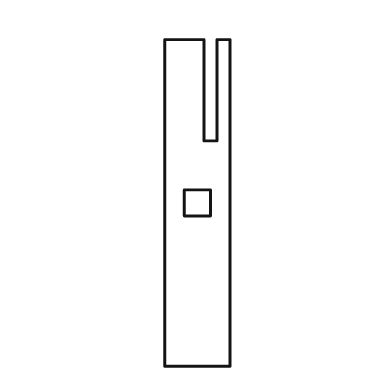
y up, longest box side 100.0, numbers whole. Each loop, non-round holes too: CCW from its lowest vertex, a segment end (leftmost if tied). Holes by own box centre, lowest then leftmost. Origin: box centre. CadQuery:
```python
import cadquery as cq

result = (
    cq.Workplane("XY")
    .moveTo(-10.0, -50.0)
    .lineTo(10.0, -50.0)
    .lineTo(10.0, 50.0)
    .lineTo(6.0, 50.0)
    .lineTo(6.0, 19.0)
    .lineTo(2.0, 19.0)
    .lineTo(2.0, 50.0)
    .lineTo(-10.0, 50.0)
    .close()
    .moveTo(-4.0, -4.0)
    .lineTo(4.0, -4.0)
    .lineTo(4.0, 4.0)
    .lineTo(-4.0, 4.0)
    .close()
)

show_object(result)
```